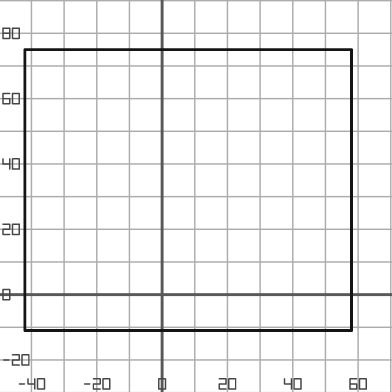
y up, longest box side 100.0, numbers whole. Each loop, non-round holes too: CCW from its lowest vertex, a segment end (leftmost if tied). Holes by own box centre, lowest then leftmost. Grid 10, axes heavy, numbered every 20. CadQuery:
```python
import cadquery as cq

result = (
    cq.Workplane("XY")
    .moveTo(-42.0, -11.0)
    .lineTo(58.0, -11.0)
    .lineTo(58.0, 75.0)
    .lineTo(-42.0, 75.0)
    .close()
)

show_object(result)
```